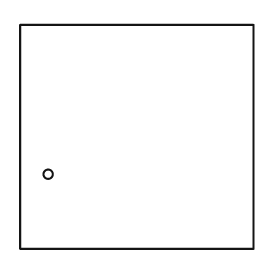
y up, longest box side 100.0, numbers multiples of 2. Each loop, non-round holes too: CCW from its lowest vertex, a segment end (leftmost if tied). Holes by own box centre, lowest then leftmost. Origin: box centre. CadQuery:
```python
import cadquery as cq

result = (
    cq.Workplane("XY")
    .moveTo(-50.0, -48.0)
    .lineTo(50.0, -48.0)
    .lineTo(50.0, 48.0)
    .lineTo(-50.0, 48.0)
    .close()
    .moveTo(-38.0, -16.0)
    .circle(2.0)
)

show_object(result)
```